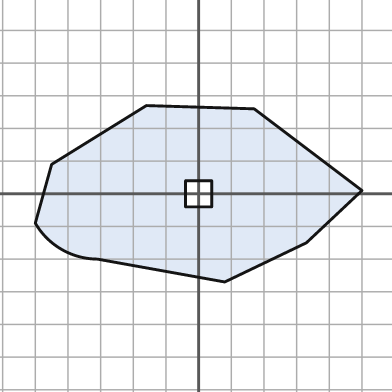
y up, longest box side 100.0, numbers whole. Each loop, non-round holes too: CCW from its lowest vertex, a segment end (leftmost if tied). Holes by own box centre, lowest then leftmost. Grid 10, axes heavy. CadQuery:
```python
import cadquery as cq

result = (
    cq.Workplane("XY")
    .moveTo(8.0, -27.0)
    .lineTo(33.0, -15.0)
    .lineTo(50.0, 1.0)
    .lineTo(17.0, 26.0)
    .lineTo(-16.0, 27.0)
    .lineTo(-45.0, 9.0)
    .lineTo(-50.0, -9.0)
    .threePointArc((-42.0, -17.0), (-31.0, -20.0))
    .close()
    .moveTo(-4.0, -4.0)
    .lineTo(4.0, -4.0)
    .lineTo(4.0, 4.0)
    .lineTo(-4.0, 4.0)
    .close()
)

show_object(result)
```